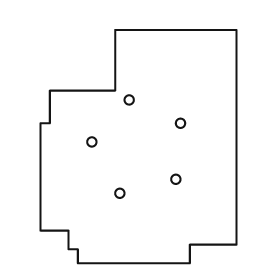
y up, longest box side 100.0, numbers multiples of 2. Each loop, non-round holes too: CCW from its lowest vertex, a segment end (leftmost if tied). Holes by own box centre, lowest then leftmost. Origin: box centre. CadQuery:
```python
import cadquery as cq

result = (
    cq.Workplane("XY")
    .moveTo(-26.0, -50.0)
    .lineTo(22.0, -50.0)
    .lineTo(22.0, -42.0)
    .lineTo(42.0, -42.0)
    .lineTo(42.0, 50.0)
    .lineTo(-10.0, 50.0)
    .lineTo(-10.0, 24.0)
    .lineTo(-38.0, 24.0)
    .lineTo(-38.0, 10.0)
    .lineTo(-42.0, 10.0)
    .lineTo(-42.0, -36.0)
    .lineTo(-30.0, -36.0)
    .lineTo(-30.0, -44.0)
    .lineTo(-26.0, -44.0)
    .close()
    .moveTo(-8.0, -20.0)
    .circle(2.0)
    .moveTo(16.0, -14.0)
    .circle(2.0)
    .moveTo(-20.0, 2.0)
    .circle(2.0)
    .moveTo(18.0, 10.0)
    .circle(2.0)
    .moveTo(-4.0, 20.0)
    .circle(2.0)
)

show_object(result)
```